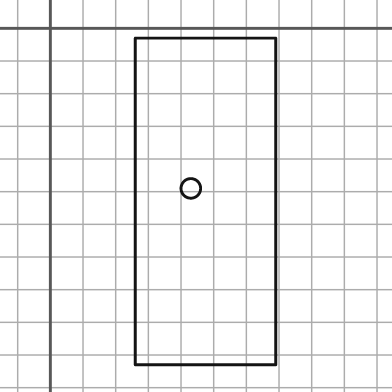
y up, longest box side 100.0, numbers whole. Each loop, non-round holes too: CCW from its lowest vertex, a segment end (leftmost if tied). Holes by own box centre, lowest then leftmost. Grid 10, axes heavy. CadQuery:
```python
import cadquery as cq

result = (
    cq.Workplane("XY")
    .moveTo(26.0, -103.0)
    .lineTo(69.0, -103.0)
    .lineTo(69.0, -3.0)
    .lineTo(26.0, -3.0)
    .close()
    .moveTo(43.0, -49.0)
    .circle(3.0)
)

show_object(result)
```